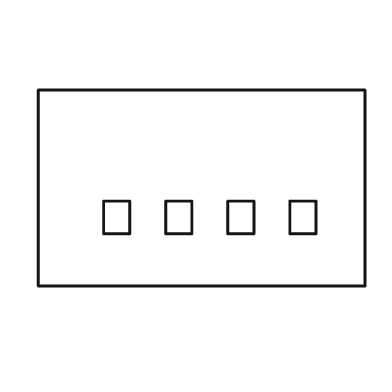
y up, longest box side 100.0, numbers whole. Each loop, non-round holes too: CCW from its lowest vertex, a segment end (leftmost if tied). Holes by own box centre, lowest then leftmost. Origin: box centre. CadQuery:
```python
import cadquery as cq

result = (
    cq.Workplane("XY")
    .moveTo(-50.0, -30.0)
    .lineTo(50.0, -30.0)
    .lineTo(50.0, 30.0)
    .lineTo(-50.0, 30.0)
    .close()
    .moveTo(-30.0, -14.0)
    .lineTo(-22.0, -14.0)
    .lineTo(-22.0, -4.0)
    .lineTo(-30.0, -4.0)
    .close()
    .moveTo(-11.0, -14.0)
    .lineTo(-3.0, -14.0)
    .lineTo(-3.0, -4.0)
    .lineTo(-11.0, -4.0)
    .close()
    .moveTo(8.0, -14.0)
    .lineTo(16.0, -14.0)
    .lineTo(16.0, -4.0)
    .lineTo(8.0, -4.0)
    .close()
    .moveTo(27.0, -14.0)
    .lineTo(35.0, -14.0)
    .lineTo(35.0, -4.0)
    .lineTo(27.0, -4.0)
    .close()
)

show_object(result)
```